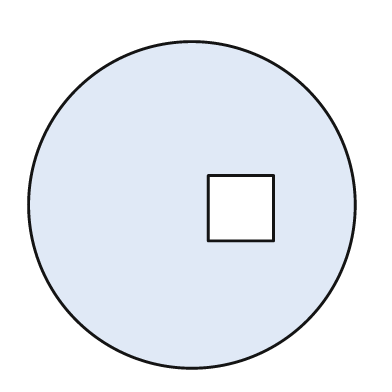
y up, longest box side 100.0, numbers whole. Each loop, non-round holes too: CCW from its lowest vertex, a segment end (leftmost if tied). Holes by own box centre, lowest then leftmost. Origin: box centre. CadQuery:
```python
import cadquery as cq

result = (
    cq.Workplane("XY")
    .moveTo(0.0, 0.0)
    .circle(50.0)
    .moveTo(5.0, -11.0)
    .lineTo(25.0, -11.0)
    .lineTo(25.0, 9.0)
    .lineTo(5.0, 9.0)
    .close()
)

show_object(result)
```